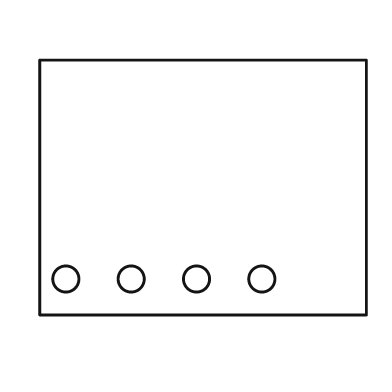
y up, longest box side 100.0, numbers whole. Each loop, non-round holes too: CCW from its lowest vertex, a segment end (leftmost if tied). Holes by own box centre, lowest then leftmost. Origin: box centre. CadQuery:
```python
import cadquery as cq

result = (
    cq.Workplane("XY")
    .moveTo(-50.0, -39.0)
    .lineTo(50.0, -39.0)
    .lineTo(50.0, 39.0)
    .lineTo(-50.0, 39.0)
    .close()
    .moveTo(-42.0, -28.0)
    .circle(4.0)
    .moveTo(-22.0, -28.0)
    .circle(4.0)
    .moveTo(-2.0, -28.0)
    .circle(4.0)
    .moveTo(18.0, -28.0)
    .circle(4.0)
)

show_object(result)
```